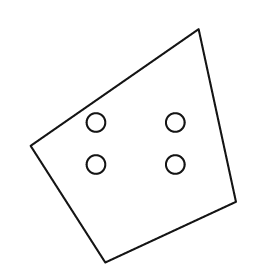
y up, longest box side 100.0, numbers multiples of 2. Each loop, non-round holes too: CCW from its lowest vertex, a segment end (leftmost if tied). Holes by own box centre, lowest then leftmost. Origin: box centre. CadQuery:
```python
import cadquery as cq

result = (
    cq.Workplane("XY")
    .moveTo(-12.0, -50.0)
    .lineTo(44.0, -24.0)
    .lineTo(28.0, 50.0)
    .lineTo(-44.0, 0.0)
    .close()
    .moveTo(-16.0, -8.0)
    .circle(4.0)
    .moveTo(18.0, -8.0)
    .circle(4.0)
    .moveTo(-16.0, 10.0)
    .circle(4.0)
    .moveTo(18.0, 10.0)
    .circle(4.0)
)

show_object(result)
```